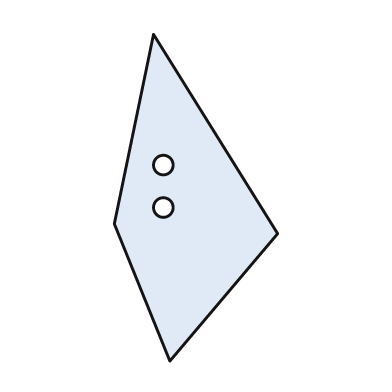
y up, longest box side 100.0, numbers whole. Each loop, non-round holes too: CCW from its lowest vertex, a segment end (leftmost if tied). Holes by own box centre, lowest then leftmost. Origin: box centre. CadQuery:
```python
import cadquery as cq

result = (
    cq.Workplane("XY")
    .moveTo(-8.0, -50.0)
    .lineTo(25.0, -11.0)
    .lineTo(-13.0, 50.0)
    .lineTo(-25.0, -8.0)
    .close()
    .moveTo(-10.0, -3.0)
    .circle(3.0)
    .moveTo(-10.0, 10.0)
    .circle(3.0)
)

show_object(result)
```